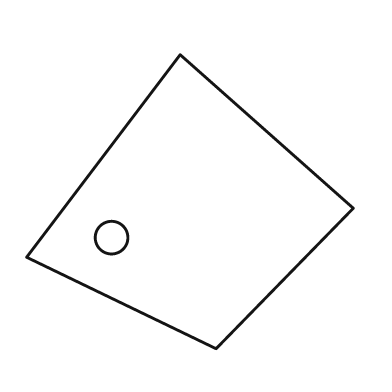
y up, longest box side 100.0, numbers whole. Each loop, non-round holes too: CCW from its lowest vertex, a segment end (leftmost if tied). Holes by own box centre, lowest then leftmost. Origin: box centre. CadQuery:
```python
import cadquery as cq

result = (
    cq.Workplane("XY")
    .moveTo(8.0, -45.0)
    .lineTo(50.0, -2.0)
    .lineTo(-3.0, 45.0)
    .lineTo(-50.0, -17.0)
    .close()
    .moveTo(-24.0, -11.0)
    .circle(5.0)
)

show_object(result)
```